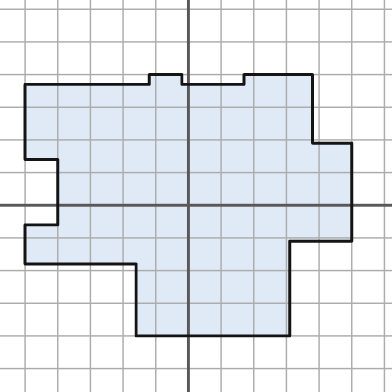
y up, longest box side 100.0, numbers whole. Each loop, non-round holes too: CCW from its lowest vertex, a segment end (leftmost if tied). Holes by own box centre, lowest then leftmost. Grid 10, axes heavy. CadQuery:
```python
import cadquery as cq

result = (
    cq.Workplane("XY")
    .moveTo(-16.0, -40.0)
    .lineTo(31.0, -40.0)
    .lineTo(31.0, -11.0)
    .lineTo(50.0, -11.0)
    .lineTo(50.0, 19.0)
    .lineTo(38.0, 19.0)
    .lineTo(38.0, 40.0)
    .lineTo(17.0, 40.0)
    .lineTo(17.0, 37.0)
    .lineTo(-2.0, 37.0)
    .lineTo(-2.0, 40.0)
    .lineTo(-12.0, 40.0)
    .lineTo(-12.0, 37.0)
    .lineTo(-50.0, 37.0)
    .lineTo(-50.0, 14.0)
    .lineTo(-40.0, 14.0)
    .lineTo(-40.0, -6.0)
    .lineTo(-50.0, -6.0)
    .lineTo(-50.0, -18.0)
    .lineTo(-16.0, -18.0)
    .close()
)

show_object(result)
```